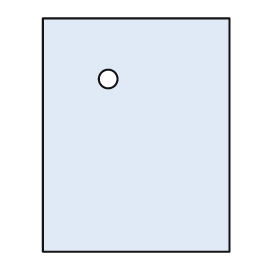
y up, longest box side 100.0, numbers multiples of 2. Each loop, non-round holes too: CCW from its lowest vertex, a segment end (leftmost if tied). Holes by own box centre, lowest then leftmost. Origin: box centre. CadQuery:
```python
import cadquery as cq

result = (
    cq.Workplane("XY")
    .moveTo(-40.0, -50.0)
    .lineTo(40.0, -50.0)
    .lineTo(40.0, 50.0)
    .lineTo(-40.0, 50.0)
    .close()
    .moveTo(-12.0, 24.0)
    .circle(4.0)
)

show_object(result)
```